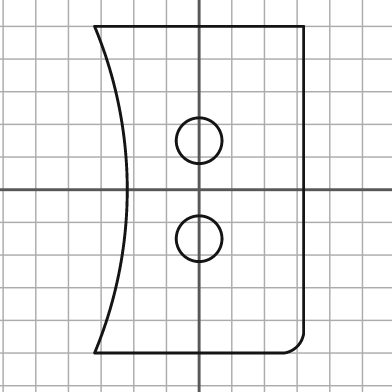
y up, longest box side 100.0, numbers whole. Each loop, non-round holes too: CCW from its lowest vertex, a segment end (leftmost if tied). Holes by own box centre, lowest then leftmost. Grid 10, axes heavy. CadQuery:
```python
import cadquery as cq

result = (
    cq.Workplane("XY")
    .moveTo(-32.0, -50.0)
    .lineTo(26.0, -50.0)
    .threePointArc((30.0, -48.0), (32.0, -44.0))
    .lineTo(32.0, 50.0)
    .lineTo(-32.0, 50.0)
    .threePointArc((-22.0, 0.0), (-32.0, -50.0))
    .close()
    .moveTo(0.0, -15.0)
    .circle(7.0)
    .moveTo(0.0, 15.0)
    .circle(7.0)
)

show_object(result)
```